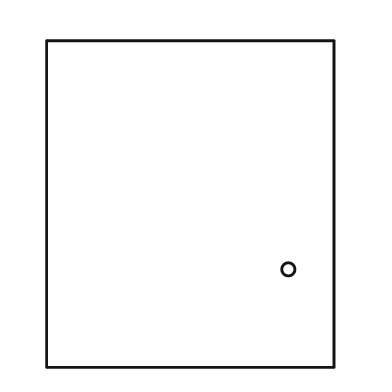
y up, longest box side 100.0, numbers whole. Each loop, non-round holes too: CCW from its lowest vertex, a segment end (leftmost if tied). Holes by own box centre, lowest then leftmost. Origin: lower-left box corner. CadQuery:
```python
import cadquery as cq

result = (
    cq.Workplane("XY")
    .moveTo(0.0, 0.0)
    .lineTo(88.0, 0.0)
    .lineTo(88.0, 100.0)
    .lineTo(0.0, 100.0)
    .close()
    .moveTo(74.0, 30.0)
    .circle(2.0)
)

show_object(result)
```